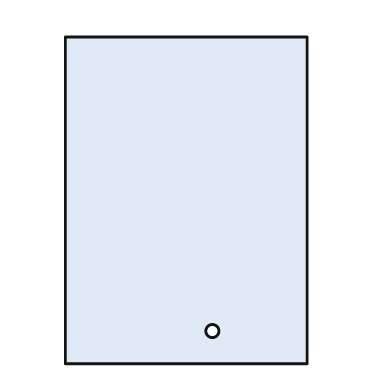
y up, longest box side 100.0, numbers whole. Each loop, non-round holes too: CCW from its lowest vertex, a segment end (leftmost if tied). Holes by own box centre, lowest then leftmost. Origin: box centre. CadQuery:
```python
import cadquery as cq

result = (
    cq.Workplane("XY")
    .moveTo(-37.0, -50.0)
    .lineTo(37.0, -50.0)
    .lineTo(37.0, 50.0)
    .lineTo(-37.0, 50.0)
    .close()
    .moveTo(8.0, -40.0)
    .circle(2.0)
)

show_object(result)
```